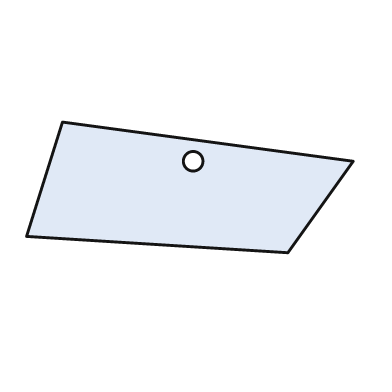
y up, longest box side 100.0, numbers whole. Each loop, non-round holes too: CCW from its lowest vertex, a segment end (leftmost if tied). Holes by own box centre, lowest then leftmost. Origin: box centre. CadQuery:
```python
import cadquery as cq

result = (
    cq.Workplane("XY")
    .moveTo(30.0, -20.0)
    .lineTo(50.0, 8.0)
    .lineTo(-39.0, 20.0)
    .lineTo(-50.0, -15.0)
    .close()
    .moveTo(1.0, 8.0)
    .circle(3.0)
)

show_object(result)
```